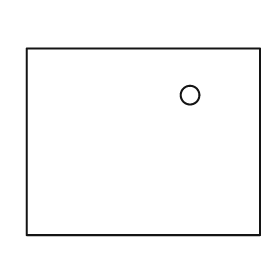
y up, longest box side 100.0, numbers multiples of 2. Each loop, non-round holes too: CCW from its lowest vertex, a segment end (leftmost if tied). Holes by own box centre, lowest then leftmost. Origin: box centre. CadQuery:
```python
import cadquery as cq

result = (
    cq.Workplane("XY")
    .moveTo(-50.0, -40.0)
    .lineTo(50.0, -40.0)
    .lineTo(50.0, 40.0)
    .lineTo(-50.0, 40.0)
    .close()
    .moveTo(20.0, 20.0)
    .circle(4.0)
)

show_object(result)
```